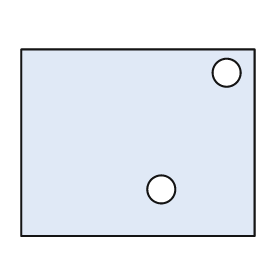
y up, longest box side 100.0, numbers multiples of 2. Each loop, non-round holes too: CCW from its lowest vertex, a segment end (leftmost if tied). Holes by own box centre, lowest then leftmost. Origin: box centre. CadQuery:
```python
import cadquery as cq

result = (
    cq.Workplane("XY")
    .moveTo(-50.0, -40.0)
    .lineTo(50.0, -40.0)
    .lineTo(50.0, 40.0)
    .lineTo(-50.0, 40.0)
    .close()
    .moveTo(10.0, -20.0)
    .circle(6.0)
    .moveTo(38.0, 30.0)
    .circle(6.0)
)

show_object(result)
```